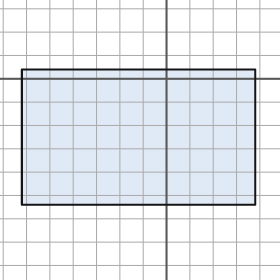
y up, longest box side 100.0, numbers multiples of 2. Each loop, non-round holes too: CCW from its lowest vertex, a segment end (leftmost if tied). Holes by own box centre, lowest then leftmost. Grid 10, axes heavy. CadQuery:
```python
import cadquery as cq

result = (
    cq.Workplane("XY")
    .moveTo(-62.0, -54.0)
    .lineTo(38.0, -54.0)
    .lineTo(38.0, 4.0)
    .lineTo(-62.0, 4.0)
    .close()
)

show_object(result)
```